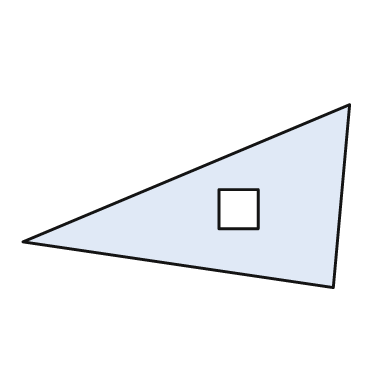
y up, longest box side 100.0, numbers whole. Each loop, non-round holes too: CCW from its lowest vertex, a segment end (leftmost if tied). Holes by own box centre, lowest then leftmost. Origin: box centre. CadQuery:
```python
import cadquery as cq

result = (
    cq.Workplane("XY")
    .moveTo(45.0, -28.0)
    .lineTo(50.0, 28.0)
    .lineTo(-50.0, -14.0)
    .close()
    .moveTo(10.0, -10.0)
    .lineTo(22.0, -10.0)
    .lineTo(22.0, 2.0)
    .lineTo(10.0, 2.0)
    .close()
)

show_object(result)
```